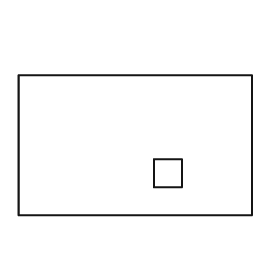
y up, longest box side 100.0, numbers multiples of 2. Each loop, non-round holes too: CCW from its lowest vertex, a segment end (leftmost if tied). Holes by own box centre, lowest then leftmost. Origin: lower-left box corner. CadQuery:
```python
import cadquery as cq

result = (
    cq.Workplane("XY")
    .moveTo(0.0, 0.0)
    .lineTo(100.0, 0.0)
    .lineTo(100.0, 60.0)
    .lineTo(0.0, 60.0)
    .close()
    .moveTo(58.0, 12.0)
    .lineTo(70.0, 12.0)
    .lineTo(70.0, 24.0)
    .lineTo(58.0, 24.0)
    .close()
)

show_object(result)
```